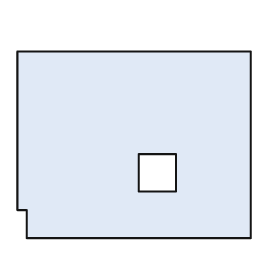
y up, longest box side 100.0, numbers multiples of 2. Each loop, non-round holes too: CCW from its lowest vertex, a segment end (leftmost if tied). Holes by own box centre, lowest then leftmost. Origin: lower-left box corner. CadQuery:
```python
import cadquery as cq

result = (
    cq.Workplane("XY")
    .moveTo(4.0, 0.0)
    .lineTo(100.0, 0.0)
    .lineTo(100.0, 80.0)
    .lineTo(0.0, 80.0)
    .lineTo(0.0, 12.0)
    .lineTo(4.0, 12.0)
    .close()
    .moveTo(52.0, 20.0)
    .lineTo(68.0, 20.0)
    .lineTo(68.0, 36.0)
    .lineTo(52.0, 36.0)
    .close()
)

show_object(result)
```